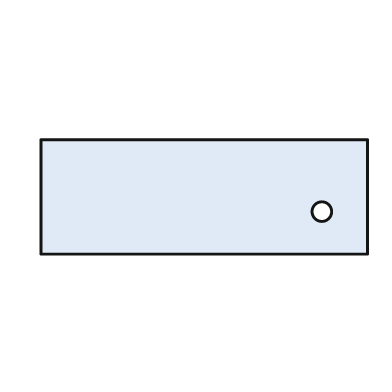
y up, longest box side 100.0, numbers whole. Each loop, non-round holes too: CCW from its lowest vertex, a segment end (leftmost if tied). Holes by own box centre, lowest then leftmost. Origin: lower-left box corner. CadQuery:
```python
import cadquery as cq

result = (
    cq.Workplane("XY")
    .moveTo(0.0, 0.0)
    .lineTo(100.0, 0.0)
    .lineTo(100.0, 35.0)
    .lineTo(0.0, 35.0)
    .close()
    .moveTo(86.0, 13.0)
    .circle(3.0)
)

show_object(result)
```